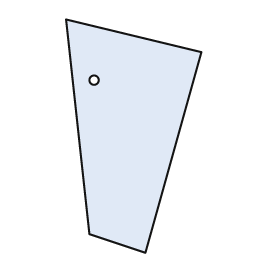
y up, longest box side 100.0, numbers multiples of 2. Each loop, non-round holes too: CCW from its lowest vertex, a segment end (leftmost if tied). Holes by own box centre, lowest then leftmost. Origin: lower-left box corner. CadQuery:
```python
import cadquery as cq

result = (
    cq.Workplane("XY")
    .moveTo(34.0, 0.0)
    .lineTo(58.0, 86.0)
    .lineTo(0.0, 100.0)
    .lineTo(10.0, 8.0)
    .close()
    .moveTo(12.0, 74.0)
    .circle(2.0)
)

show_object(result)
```